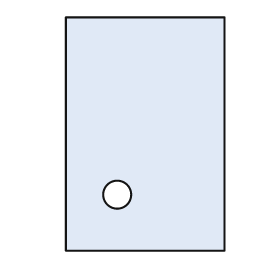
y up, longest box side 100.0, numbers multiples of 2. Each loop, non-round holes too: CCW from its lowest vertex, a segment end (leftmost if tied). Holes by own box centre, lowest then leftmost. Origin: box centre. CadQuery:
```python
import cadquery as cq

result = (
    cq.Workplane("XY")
    .moveTo(-34.0, -50.0)
    .lineTo(34.0, -50.0)
    .lineTo(34.0, 50.0)
    .lineTo(-34.0, 50.0)
    .close()
    .moveTo(-12.0, -26.0)
    .circle(6.0)
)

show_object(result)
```